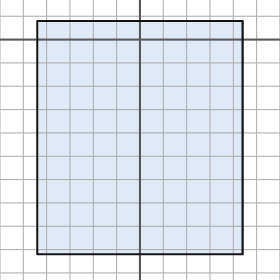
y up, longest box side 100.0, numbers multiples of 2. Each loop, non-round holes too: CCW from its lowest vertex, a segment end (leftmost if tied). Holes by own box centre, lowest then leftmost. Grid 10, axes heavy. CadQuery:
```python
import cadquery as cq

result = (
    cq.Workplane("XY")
    .moveTo(-44.0, -92.0)
    .lineTo(44.0, -92.0)
    .lineTo(44.0, 8.0)
    .lineTo(-44.0, 8.0)
    .close()
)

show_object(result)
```